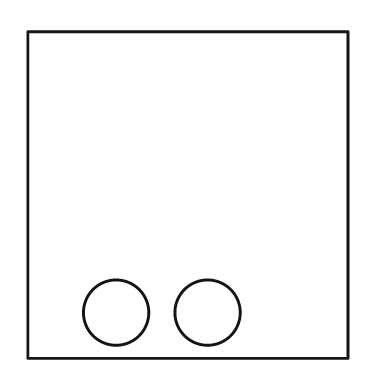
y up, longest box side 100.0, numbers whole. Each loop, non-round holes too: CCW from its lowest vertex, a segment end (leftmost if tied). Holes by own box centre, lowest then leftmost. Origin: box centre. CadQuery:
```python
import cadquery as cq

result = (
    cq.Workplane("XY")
    .moveTo(-49.0, -50.0)
    .lineTo(49.0, -50.0)
    .lineTo(49.0, 50.0)
    .lineTo(-49.0, 50.0)
    .close()
    .moveTo(-22.0, -36.0)
    .circle(10.0)
    .moveTo(6.0, -36.0)
    .circle(10.0)
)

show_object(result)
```